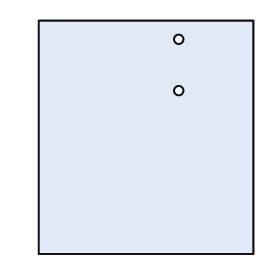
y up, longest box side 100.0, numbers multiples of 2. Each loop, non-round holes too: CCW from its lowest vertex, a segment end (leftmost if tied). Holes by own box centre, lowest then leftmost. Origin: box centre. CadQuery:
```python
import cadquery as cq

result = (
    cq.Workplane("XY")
    .moveTo(-46.0, -50.0)
    .lineTo(46.0, -50.0)
    .lineTo(46.0, 50.0)
    .lineTo(-46.0, 50.0)
    .close()
    .moveTo(14.0, 20.0)
    .circle(2.0)
    .moveTo(14.0, 42.0)
    .circle(2.0)
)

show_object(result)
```